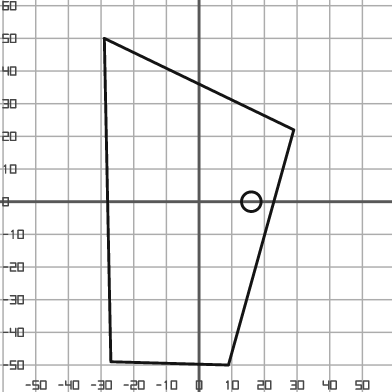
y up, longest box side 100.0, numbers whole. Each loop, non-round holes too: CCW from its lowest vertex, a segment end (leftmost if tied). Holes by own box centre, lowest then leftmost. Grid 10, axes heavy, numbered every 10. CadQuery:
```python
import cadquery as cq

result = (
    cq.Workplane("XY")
    .moveTo(9.0, -50.0)
    .lineTo(29.0, 22.0)
    .lineTo(-29.0, 50.0)
    .lineTo(-27.0, -49.0)
    .close()
    .moveTo(16.0, 0.0)
    .circle(3.0)
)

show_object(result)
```